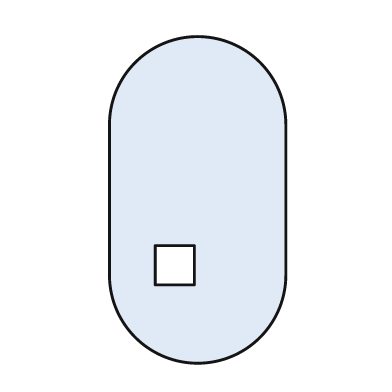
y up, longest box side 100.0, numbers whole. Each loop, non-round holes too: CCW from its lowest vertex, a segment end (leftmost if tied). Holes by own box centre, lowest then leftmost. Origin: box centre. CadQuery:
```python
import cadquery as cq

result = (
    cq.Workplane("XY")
    .moveTo(-27.0, -23.0)
    .threePointArc((0.0, -50.0), (27.0, -23.0))
    .lineTo(27.0, 23.0)
    .threePointArc((0.0, 50.0), (-27.0, 23.0))
    .close()
    .moveTo(-13.0, -26.0)
    .lineTo(-1.0, -26.0)
    .lineTo(-1.0, -14.0)
    .lineTo(-13.0, -14.0)
    .close()
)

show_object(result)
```